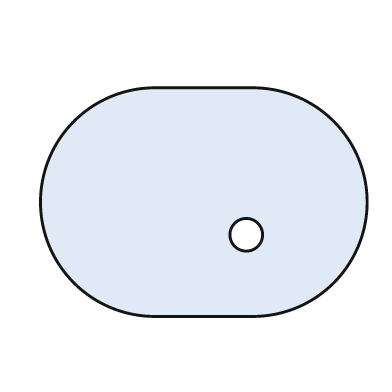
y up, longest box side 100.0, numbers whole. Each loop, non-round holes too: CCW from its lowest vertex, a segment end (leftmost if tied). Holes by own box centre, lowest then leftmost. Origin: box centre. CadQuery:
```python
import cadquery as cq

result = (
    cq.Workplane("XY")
    .moveTo(-15.0, -35.0)
    .lineTo(15.0, -35.0)
    .threePointArc((50.0, 0.0), (15.0, 35.0))
    .lineTo(-15.0, 35.0)
    .threePointArc((-50.0, 0.0), (-15.0, -35.0))
    .close()
    .moveTo(13.0, -10.0)
    .circle(5.0)
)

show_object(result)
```